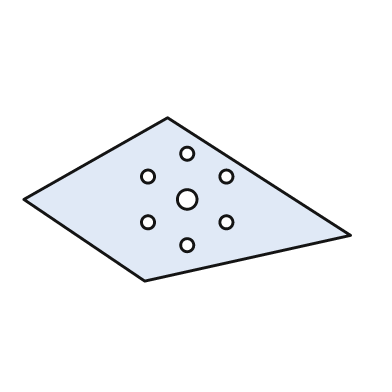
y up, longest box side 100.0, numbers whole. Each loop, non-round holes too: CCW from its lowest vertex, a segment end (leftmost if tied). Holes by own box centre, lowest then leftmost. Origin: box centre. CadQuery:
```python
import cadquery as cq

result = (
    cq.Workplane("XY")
    .moveTo(-13.0, -25.0)
    .lineTo(50.0, -11.0)
    .lineTo(-6.0, 25.0)
    .lineTo(-50.0, 0.0)
    .close()
    .moveTo(0.0, -14.0)
    .circle(2.0)
    .moveTo(-12.0, -7.0)
    .circle(2.0)
    .moveTo(12.0, -7.0)
    .circle(2.0)
    .moveTo(0.0, 0.0)
    .circle(3.0)
    .moveTo(-12.0, 7.0)
    .circle(2.0)
    .moveTo(12.0, 7.0)
    .circle(2.0)
    .moveTo(0.0, 14.0)
    .circle(2.0)
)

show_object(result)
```